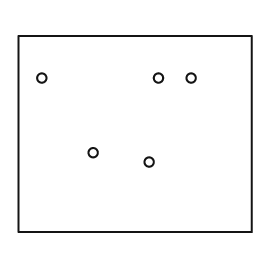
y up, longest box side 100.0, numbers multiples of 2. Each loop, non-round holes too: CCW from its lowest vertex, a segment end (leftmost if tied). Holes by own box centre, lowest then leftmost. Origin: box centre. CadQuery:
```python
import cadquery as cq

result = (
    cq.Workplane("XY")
    .moveTo(-50.0, -42.0)
    .lineTo(50.0, -42.0)
    .lineTo(50.0, 42.0)
    .lineTo(-50.0, 42.0)
    .close()
    .moveTo(6.0, -12.0)
    .circle(2.0)
    .moveTo(-18.0, -8.0)
    .circle(2.0)
    .moveTo(-40.0, 24.0)
    .circle(2.0)
    .moveTo(10.0, 24.0)
    .circle(2.0)
    .moveTo(24.0, 24.0)
    .circle(2.0)
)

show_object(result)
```